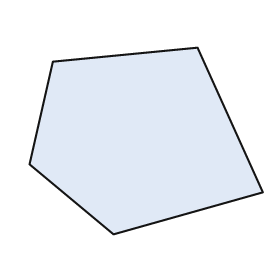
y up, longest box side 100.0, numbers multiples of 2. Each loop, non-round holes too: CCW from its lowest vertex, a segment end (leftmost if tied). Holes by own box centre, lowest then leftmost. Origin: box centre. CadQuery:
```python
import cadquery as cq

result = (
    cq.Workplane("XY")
    .moveTo(-14.0, -40.0)
    .lineTo(50.0, -22.0)
    .lineTo(22.0, 40.0)
    .lineTo(-40.0, 34.0)
    .lineTo(-50.0, -10.0)
    .close()
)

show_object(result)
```